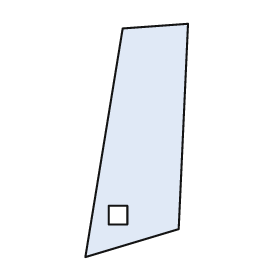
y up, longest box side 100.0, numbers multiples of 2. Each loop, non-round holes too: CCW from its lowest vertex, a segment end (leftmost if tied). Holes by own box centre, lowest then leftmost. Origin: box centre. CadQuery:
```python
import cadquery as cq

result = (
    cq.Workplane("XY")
    .moveTo(-22.0, -50.0)
    .lineTo(18.0, -38.0)
    .lineTo(22.0, 50.0)
    .lineTo(-6.0, 48.0)
    .close()
    .moveTo(-12.0, -36.0)
    .lineTo(-4.0, -36.0)
    .lineTo(-4.0, -28.0)
    .lineTo(-12.0, -28.0)
    .close()
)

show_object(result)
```